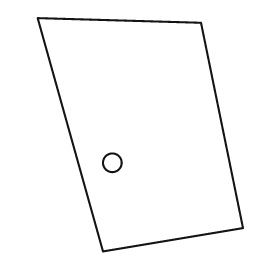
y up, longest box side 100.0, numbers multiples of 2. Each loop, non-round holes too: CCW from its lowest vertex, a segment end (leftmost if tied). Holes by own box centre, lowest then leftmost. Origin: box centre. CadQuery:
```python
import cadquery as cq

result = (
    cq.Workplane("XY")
    .moveTo(-16.0, -50.0)
    .lineTo(44.0, -40.0)
    .lineTo(26.0, 48.0)
    .lineTo(-44.0, 50.0)
    .close()
    .moveTo(-12.0, -12.0)
    .circle(4.0)
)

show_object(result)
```